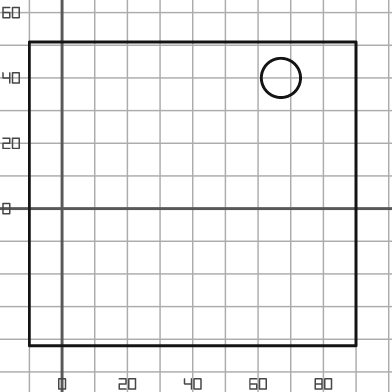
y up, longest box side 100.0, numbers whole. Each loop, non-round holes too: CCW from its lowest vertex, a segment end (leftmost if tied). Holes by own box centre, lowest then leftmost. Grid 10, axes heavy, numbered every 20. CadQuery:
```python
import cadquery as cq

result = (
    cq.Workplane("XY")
    .moveTo(-10.0, -42.0)
    .lineTo(90.0, -42.0)
    .lineTo(90.0, 51.0)
    .lineTo(-10.0, 51.0)
    .close()
    .moveTo(67.0, 40.0)
    .circle(6.0)
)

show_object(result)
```